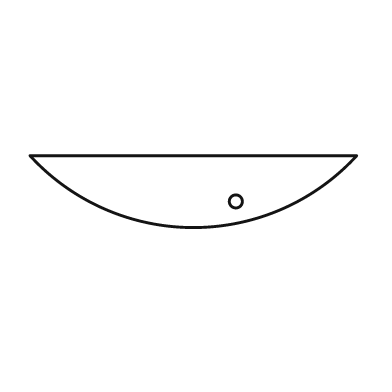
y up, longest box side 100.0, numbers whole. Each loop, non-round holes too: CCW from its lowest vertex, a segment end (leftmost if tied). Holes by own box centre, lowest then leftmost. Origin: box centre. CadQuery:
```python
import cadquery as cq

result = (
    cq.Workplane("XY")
    .moveTo(-50.0, 11.0)
    .threePointArc((0.0, -11.0), (50.0, 11.0))
    .close()
    .moveTo(13.0, -3.0)
    .circle(2.0)
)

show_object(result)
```